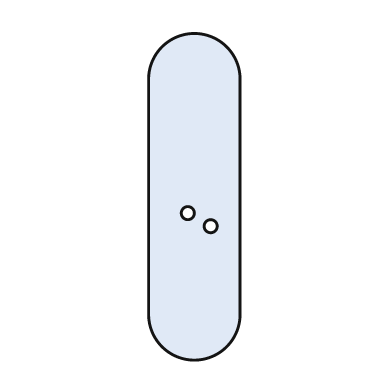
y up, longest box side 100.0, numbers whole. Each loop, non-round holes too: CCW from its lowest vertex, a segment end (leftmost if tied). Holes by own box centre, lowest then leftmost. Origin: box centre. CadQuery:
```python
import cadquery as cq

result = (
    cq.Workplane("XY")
    .moveTo(-14.0, -36.0)
    .threePointArc((0.0, -50.0), (14.0, -36.0))
    .lineTo(14.0, 36.0)
    .threePointArc((0.0, 50.0), (-14.0, 36.0))
    .close()
    .moveTo(5.0, -9.0)
    .circle(2.0)
    .moveTo(-2.0, -5.0)
    .circle(2.0)
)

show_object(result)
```